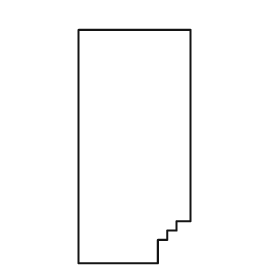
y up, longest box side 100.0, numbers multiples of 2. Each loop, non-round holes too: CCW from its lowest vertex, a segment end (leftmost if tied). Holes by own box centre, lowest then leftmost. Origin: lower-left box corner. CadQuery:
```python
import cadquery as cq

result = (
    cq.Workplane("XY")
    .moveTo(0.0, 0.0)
    .lineTo(34.0, 0.0)
    .lineTo(34.0, 10.0)
    .lineTo(38.0, 10.0)
    .lineTo(38.0, 14.0)
    .lineTo(42.0, 14.0)
    .lineTo(42.0, 18.0)
    .lineTo(48.0, 18.0)
    .lineTo(48.0, 100.0)
    .lineTo(0.0, 100.0)
    .close()
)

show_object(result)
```